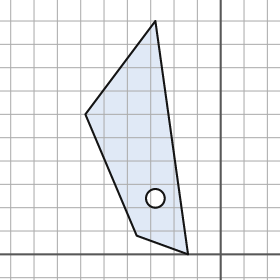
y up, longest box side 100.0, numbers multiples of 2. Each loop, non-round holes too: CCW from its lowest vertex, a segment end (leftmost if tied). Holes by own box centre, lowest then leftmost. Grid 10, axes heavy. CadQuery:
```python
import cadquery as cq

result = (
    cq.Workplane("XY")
    .moveTo(-14.0, 0.0)
    .lineTo(-28.0, 100.0)
    .lineTo(-58.0, 60.0)
    .lineTo(-36.0, 8.0)
    .close()
    .moveTo(-28.0, 24.0)
    .circle(4.0)
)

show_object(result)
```